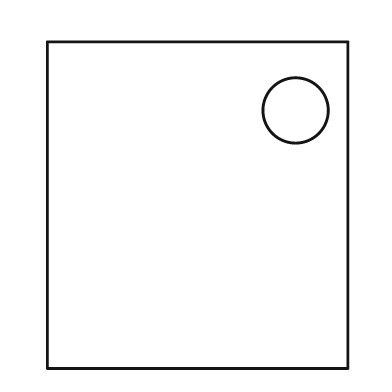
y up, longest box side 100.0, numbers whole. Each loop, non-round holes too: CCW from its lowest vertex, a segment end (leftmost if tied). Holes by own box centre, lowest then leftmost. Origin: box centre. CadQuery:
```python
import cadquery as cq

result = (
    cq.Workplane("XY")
    .moveTo(-46.0, -50.0)
    .lineTo(46.0, -50.0)
    .lineTo(46.0, 50.0)
    .lineTo(-46.0, 50.0)
    .close()
    .moveTo(30.0, 29.0)
    .circle(10.0)
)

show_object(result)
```